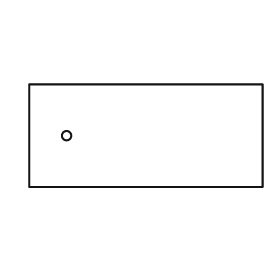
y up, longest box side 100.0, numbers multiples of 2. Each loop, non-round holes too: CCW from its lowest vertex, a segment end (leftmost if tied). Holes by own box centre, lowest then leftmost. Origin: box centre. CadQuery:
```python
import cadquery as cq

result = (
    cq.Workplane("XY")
    .moveTo(-50.0, -22.0)
    .lineTo(50.0, -22.0)
    .lineTo(50.0, 22.0)
    .lineTo(-50.0, 22.0)
    .close()
    .moveTo(-34.0, 0.0)
    .circle(2.0)
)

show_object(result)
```